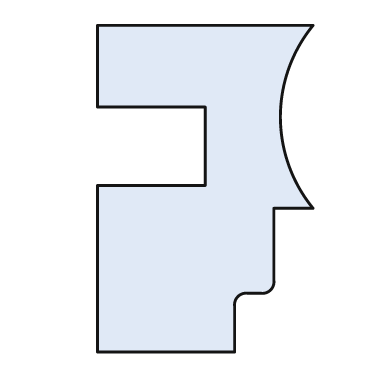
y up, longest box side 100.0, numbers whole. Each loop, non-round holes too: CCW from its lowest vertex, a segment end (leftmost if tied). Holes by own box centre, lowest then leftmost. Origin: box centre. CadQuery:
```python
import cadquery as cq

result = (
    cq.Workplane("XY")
    .moveTo(-33.0, -50.0)
    .lineTo(9.0, -50.0)
    .lineTo(9.0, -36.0)
    .threePointArc((10.0, -33.0), (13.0, -32.0))
    .lineTo(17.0, -32.0)
    .threePointArc((20.0, -31.0), (21.0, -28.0))
    .lineTo(21.0, -6.0)
    .lineTo(33.0, -6.0)
    .threePointArc((23.0, 22.0), (33.0, 50.0))
    .lineTo(-33.0, 50.0)
    .lineTo(-33.0, 25.0)
    .lineTo(0.0, 25.0)
    .lineTo(0.0, 1.0)
    .lineTo(-33.0, 1.0)
    .close()
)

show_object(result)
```